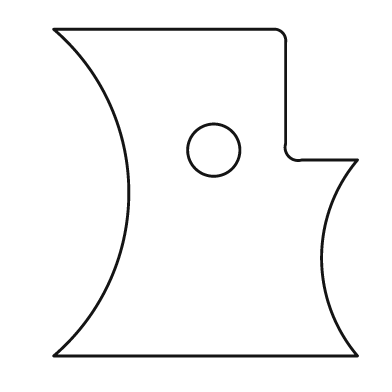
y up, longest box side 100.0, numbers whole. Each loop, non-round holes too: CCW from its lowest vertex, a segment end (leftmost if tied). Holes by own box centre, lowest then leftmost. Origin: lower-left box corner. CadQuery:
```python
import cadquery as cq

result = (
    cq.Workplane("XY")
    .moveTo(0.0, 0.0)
    .lineTo(93.0, 0.0)
    .threePointArc((82.0, 30.0), (93.0, 60.0))
    .lineTo(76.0, 60.0)
    .threePointArc((72.0, 61.0), (71.0, 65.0))
    .lineTo(71.0, 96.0)
    .threePointArc((70.0, 99.0), (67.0, 100.0))
    .lineTo(0.0, 100.0)
    .threePointArc((23.0, 50.0), (0.0, 0.0))
    .close()
    .moveTo(49.0, 63.0)
    .circle(8.0)
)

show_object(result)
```